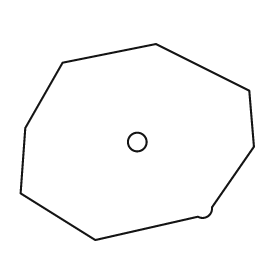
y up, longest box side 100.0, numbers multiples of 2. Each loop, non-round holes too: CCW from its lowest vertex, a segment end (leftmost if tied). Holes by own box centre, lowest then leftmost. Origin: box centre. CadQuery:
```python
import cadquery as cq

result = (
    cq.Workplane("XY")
    .moveTo(-18.0, -42.0)
    .lineTo(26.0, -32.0)
    .threePointArc((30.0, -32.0), (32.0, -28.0))
    .lineTo(50.0, -2.0)
    .lineTo(48.0, 22.0)
    .lineTo(8.0, 42.0)
    .lineTo(-32.0, 34.0)
    .lineTo(-48.0, 6.0)
    .lineTo(-50.0, -22.0)
    .close()
    .moveTo(0.0, 0.0)
    .circle(4.0)
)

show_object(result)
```